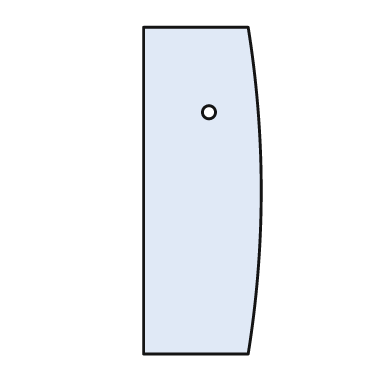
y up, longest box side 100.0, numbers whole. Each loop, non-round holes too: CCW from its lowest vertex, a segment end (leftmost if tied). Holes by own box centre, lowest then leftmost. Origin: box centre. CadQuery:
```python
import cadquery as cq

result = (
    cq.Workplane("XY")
    .moveTo(-18.0, -50.0)
    .lineTo(14.0, -50.0)
    .threePointArc((18.0, 0.0), (14.0, 50.0))
    .lineTo(-18.0, 50.0)
    .close()
    .moveTo(2.0, 24.0)
    .circle(2.0)
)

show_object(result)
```